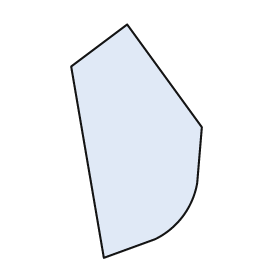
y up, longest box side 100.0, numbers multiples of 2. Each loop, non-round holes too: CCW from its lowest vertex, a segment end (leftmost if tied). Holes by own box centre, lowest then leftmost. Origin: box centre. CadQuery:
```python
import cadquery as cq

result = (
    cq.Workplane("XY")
    .moveTo(-14.0, -50.0)
    .lineTo(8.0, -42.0)
    .threePointArc((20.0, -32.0), (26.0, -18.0))
    .lineTo(28.0, 6.0)
    .lineTo(-4.0, 50.0)
    .lineTo(-28.0, 32.0)
    .close()
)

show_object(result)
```